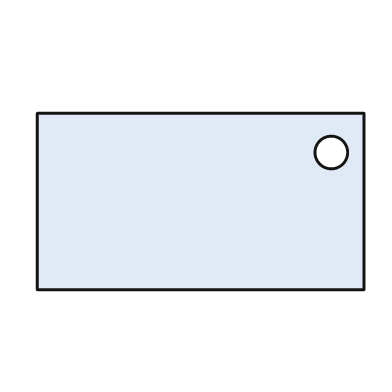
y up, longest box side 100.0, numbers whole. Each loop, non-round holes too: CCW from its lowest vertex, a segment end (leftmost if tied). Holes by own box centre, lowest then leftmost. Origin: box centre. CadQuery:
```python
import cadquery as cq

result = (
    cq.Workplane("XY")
    .moveTo(-50.0, -27.0)
    .lineTo(50.0, -27.0)
    .lineTo(50.0, 27.0)
    .lineTo(-50.0, 27.0)
    .close()
    .moveTo(40.0, 15.0)
    .circle(5.0)
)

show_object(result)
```